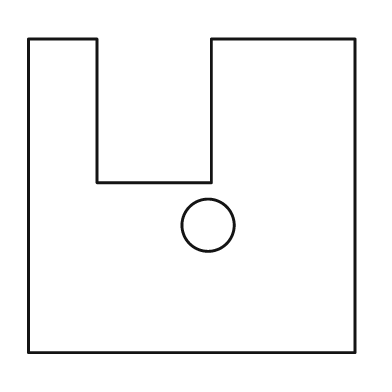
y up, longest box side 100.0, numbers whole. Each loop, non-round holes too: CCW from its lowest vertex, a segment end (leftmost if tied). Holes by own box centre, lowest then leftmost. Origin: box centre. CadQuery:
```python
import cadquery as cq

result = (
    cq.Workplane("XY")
    .moveTo(-50.0, -48.0)
    .lineTo(50.0, -48.0)
    .lineTo(50.0, 48.0)
    .lineTo(6.0, 48.0)
    .lineTo(6.0, 4.0)
    .lineTo(-29.0, 4.0)
    .lineTo(-29.0, 48.0)
    .lineTo(-50.0, 48.0)
    .close()
    .moveTo(5.0, -9.0)
    .circle(8.0)
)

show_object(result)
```